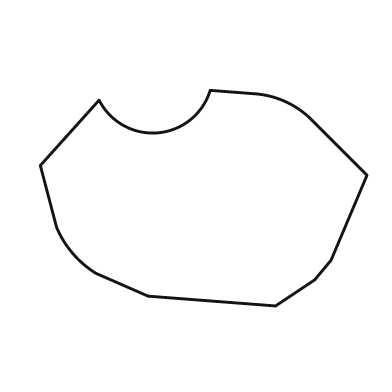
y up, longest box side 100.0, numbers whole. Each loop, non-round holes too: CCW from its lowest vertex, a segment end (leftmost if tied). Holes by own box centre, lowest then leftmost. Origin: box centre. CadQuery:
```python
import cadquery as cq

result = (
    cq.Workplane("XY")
    .moveTo(22.0, -33.0)
    .lineTo(34.0, -25.0)
    .lineTo(39.0, -19.0)
    .lineTo(50.0, 7.0)
    .lineTo(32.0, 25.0)
    .threePointArc((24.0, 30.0), (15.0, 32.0))
    .lineTo(2.0, 33.0)
    .threePointArc((-14.0, 20.0), (-32.0, 30.0))
    .lineTo(-50.0, 10.0)
    .lineTo(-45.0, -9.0)
    .threePointArc((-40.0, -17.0), (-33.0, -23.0))
    .lineTo(-17.0, -30.0)
    .close()
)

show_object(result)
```